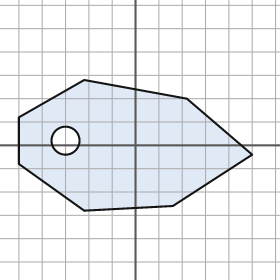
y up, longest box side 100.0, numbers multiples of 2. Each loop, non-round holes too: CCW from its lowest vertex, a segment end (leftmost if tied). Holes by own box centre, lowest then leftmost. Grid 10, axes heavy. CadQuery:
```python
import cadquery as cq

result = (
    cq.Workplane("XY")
    .moveTo(-22.0, -28.0)
    .lineTo(16.0, -26.0)
    .lineTo(50.0, -4.0)
    .lineTo(22.0, 20.0)
    .lineTo(-22.0, 28.0)
    .lineTo(-50.0, 12.0)
    .lineTo(-50.0, -8.0)
    .close()
    .moveTo(-30.0, 2.0)
    .circle(6.0)
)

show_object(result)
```